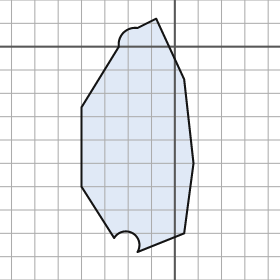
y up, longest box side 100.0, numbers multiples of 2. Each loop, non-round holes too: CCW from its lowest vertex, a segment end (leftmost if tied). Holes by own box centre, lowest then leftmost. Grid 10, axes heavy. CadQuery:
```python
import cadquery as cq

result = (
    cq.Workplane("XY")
    .moveTo(-16.0, -88.0)
    .lineTo(4.0, -80.0)
    .lineTo(8.0, -50.0)
    .lineTo(4.0, -14.0)
    .lineTo(-8.0, 12.0)
    .lineTo(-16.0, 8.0)
    .threePointArc((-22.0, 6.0), (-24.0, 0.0))
    .lineTo(-40.0, -26.0)
    .lineTo(-40.0, -60.0)
    .lineTo(-26.0, -82.0)
    .threePointArc((-18.0, -80.0), (-16.0, -88.0))
    .close()
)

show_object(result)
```